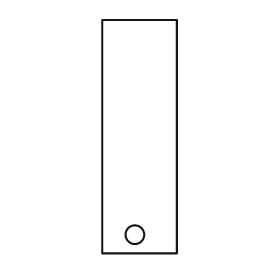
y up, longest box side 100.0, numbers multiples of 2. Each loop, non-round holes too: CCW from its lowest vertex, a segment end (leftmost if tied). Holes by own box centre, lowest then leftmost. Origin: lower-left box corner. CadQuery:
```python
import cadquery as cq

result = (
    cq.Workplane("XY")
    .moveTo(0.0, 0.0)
    .lineTo(32.0, 0.0)
    .lineTo(32.0, 100.0)
    .lineTo(0.0, 100.0)
    .close()
    .moveTo(14.0, 8.0)
    .circle(4.0)
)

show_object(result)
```